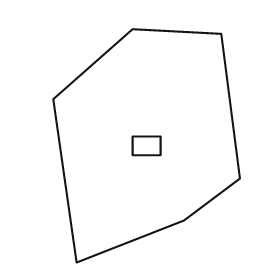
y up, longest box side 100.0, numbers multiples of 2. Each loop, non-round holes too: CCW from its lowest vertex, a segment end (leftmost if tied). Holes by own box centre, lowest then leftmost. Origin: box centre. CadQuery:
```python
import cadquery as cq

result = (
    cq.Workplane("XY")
    .moveTo(-30.0, -50.0)
    .lineTo(16.0, -32.0)
    .lineTo(40.0, -14.0)
    .lineTo(32.0, 48.0)
    .lineTo(-6.0, 50.0)
    .lineTo(-40.0, 20.0)
    .close()
    .moveTo(-6.0, -4.0)
    .lineTo(6.0, -4.0)
    .lineTo(6.0, 4.0)
    .lineTo(-6.0, 4.0)
    .close()
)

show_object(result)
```